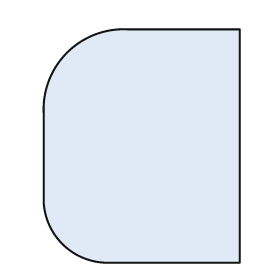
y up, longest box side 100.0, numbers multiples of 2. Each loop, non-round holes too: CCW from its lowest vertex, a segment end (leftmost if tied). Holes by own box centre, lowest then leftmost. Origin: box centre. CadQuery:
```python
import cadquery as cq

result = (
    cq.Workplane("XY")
    .moveTo(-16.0, -50.0)
    .lineTo(42.0, -50.0)
    .lineTo(42.0, 50.0)
    .lineTo(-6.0, 50.0)
    .threePointArc((-32.0, 40.0), (-42.0, 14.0))
    .lineTo(-42.0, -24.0)
    .threePointArc((-34.0, -42.0), (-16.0, -50.0))
    .close()
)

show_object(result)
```